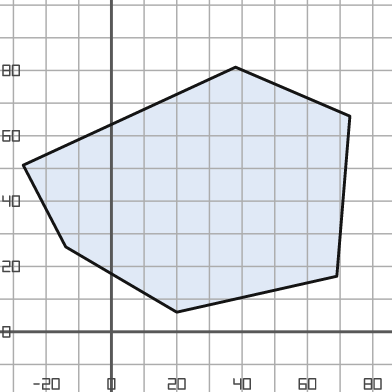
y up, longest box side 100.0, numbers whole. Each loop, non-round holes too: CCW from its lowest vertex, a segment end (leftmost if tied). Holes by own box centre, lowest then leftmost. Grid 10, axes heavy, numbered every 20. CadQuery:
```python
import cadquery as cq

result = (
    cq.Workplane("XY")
    .moveTo(20.0, 6.0)
    .lineTo(69.0, 17.0)
    .lineTo(73.0, 66.0)
    .lineTo(38.0, 81.0)
    .lineTo(-27.0, 51.0)
    .lineTo(-14.0, 26.0)
    .close()
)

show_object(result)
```